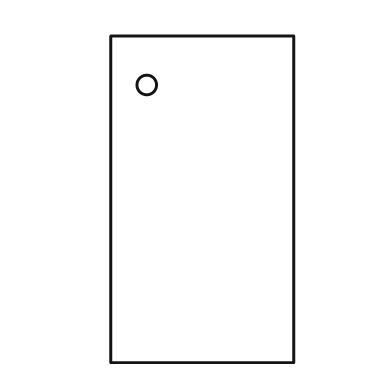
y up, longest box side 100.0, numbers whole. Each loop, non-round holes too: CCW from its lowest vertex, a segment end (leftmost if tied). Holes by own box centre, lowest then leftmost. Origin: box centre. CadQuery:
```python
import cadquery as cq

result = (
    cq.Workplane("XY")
    .moveTo(-28.0, -50.0)
    .lineTo(28.0, -50.0)
    .lineTo(28.0, 50.0)
    .lineTo(-28.0, 50.0)
    .close()
    .moveTo(-17.0, 35.0)
    .circle(3.0)
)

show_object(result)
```